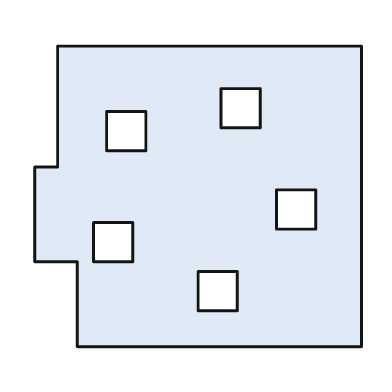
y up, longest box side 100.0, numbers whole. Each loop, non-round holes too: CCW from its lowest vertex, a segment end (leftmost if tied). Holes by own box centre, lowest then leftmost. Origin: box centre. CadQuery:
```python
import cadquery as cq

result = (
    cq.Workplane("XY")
    .moveTo(-37.0, -46.0)
    .lineTo(50.0, -46.0)
    .lineTo(50.0, 46.0)
    .lineTo(-43.0, 46.0)
    .lineTo(-43.0, 9.0)
    .lineTo(-50.0, 9.0)
    .lineTo(-50.0, -20.0)
    .lineTo(-37.0, -20.0)
    .close()
    .moveTo(0.0, -35.0)
    .lineTo(12.0, -35.0)
    .lineTo(12.0, -23.0)
    .lineTo(0.0, -23.0)
    .close()
    .moveTo(-32.0, -20.0)
    .lineTo(-20.0, -20.0)
    .lineTo(-20.0, -8.0)
    .lineTo(-32.0, -8.0)
    .close()
    .moveTo(24.0, -10.0)
    .lineTo(36.0, -10.0)
    .lineTo(36.0, 2.0)
    .lineTo(24.0, 2.0)
    .close()
    .moveTo(-28.0, 14.0)
    .lineTo(-16.0, 14.0)
    .lineTo(-16.0, 26.0)
    .lineTo(-28.0, 26.0)
    .close()
    .moveTo(7.0, 21.0)
    .lineTo(19.0, 21.0)
    .lineTo(19.0, 33.0)
    .lineTo(7.0, 33.0)
    .close()
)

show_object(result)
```